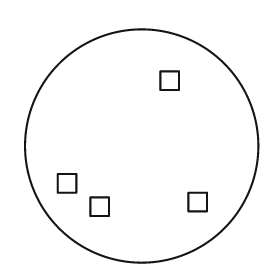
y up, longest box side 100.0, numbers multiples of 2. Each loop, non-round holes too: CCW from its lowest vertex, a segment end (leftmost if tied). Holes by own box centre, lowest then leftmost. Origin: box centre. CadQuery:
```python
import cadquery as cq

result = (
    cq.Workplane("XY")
    .moveTo(0.0, 0.0)
    .circle(50.0)
    .moveTo(-22.0, -30.0)
    .lineTo(-14.0, -30.0)
    .lineTo(-14.0, -22.0)
    .lineTo(-22.0, -22.0)
    .close()
    .moveTo(20.0, -28.0)
    .lineTo(28.0, -28.0)
    .lineTo(28.0, -20.0)
    .lineTo(20.0, -20.0)
    .close()
    .moveTo(-36.0, -20.0)
    .lineTo(-28.0, -20.0)
    .lineTo(-28.0, -12.0)
    .lineTo(-36.0, -12.0)
    .close()
    .moveTo(8.0, 24.0)
    .lineTo(16.0, 24.0)
    .lineTo(16.0, 32.0)
    .lineTo(8.0, 32.0)
    .close()
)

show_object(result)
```